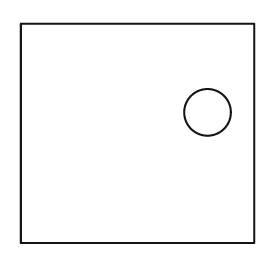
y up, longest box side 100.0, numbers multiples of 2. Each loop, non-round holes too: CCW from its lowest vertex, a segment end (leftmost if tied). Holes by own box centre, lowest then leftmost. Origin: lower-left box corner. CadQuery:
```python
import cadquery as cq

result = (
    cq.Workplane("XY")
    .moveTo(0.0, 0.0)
    .lineTo(100.0, 0.0)
    .lineTo(100.0, 94.0)
    .lineTo(0.0, 94.0)
    .close()
    .moveTo(80.0, 56.0)
    .circle(10.0)
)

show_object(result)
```